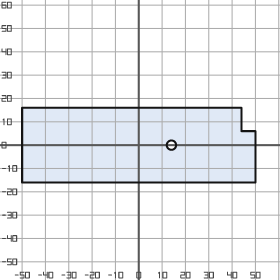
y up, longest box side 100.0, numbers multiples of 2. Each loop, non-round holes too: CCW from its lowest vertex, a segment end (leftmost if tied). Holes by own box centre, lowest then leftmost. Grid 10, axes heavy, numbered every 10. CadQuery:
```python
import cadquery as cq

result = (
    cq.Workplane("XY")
    .moveTo(-50.0, -16.0)
    .lineTo(50.0, -16.0)
    .lineTo(50.0, 6.0)
    .lineTo(44.0, 6.0)
    .lineTo(44.0, 16.0)
    .lineTo(-50.0, 16.0)
    .close()
    .moveTo(14.0, 0.0)
    .circle(2.0)
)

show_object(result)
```